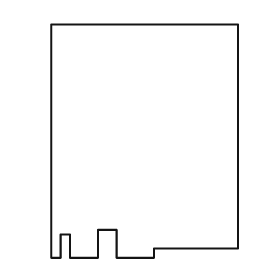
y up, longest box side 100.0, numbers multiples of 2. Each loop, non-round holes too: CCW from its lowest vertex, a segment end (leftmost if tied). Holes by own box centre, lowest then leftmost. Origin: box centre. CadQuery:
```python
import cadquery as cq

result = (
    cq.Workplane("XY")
    .moveTo(-40.0, -50.0)
    .lineTo(-36.0, -50.0)
    .lineTo(-36.0, -40.0)
    .lineTo(-32.0, -40.0)
    .lineTo(-32.0, -50.0)
    .lineTo(-20.0, -50.0)
    .lineTo(-20.0, -38.0)
    .lineTo(-12.0, -38.0)
    .lineTo(-12.0, -50.0)
    .lineTo(4.0, -50.0)
    .lineTo(4.0, -46.0)
    .lineTo(40.0, -46.0)
    .lineTo(40.0, 50.0)
    .lineTo(-40.0, 50.0)
    .close()
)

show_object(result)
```